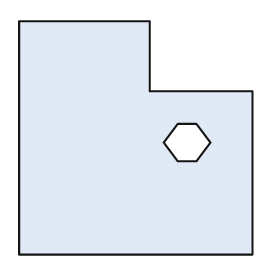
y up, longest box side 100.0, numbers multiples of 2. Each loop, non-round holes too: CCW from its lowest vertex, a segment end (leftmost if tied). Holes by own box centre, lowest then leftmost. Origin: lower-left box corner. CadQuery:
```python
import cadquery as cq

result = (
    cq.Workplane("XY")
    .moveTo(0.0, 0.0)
    .lineTo(100.0, 0.0)
    .lineTo(100.0, 70.0)
    .lineTo(56.0, 70.0)
    .lineTo(56.0, 100.0)
    .lineTo(0.0, 100.0)
    .close()
    .moveTo(68.0, 40.0)
    .lineTo(76.0, 40.0)
    .lineTo(82.0, 48.0)
    .lineTo(76.0, 56.0)
    .lineTo(68.0, 56.0)
    .lineTo(62.0, 48.0)
    .close()
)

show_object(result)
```